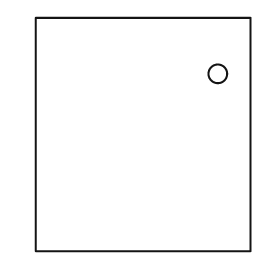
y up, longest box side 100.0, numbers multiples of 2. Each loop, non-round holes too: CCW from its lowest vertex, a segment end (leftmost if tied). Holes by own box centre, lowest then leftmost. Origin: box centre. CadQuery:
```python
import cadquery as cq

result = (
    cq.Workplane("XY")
    .moveTo(-46.0, -50.0)
    .lineTo(46.0, -50.0)
    .lineTo(46.0, 50.0)
    .lineTo(-46.0, 50.0)
    .close()
    .moveTo(32.0, 26.0)
    .circle(4.0)
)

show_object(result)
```